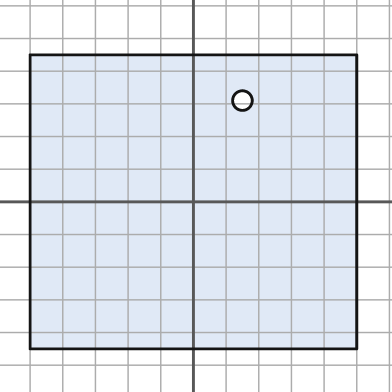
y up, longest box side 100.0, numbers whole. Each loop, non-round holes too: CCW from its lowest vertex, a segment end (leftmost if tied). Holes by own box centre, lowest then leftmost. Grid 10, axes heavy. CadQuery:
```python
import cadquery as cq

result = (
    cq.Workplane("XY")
    .moveTo(-50.0, -45.0)
    .lineTo(50.0, -45.0)
    .lineTo(50.0, 45.0)
    .lineTo(-50.0, 45.0)
    .close()
    .moveTo(15.0, 31.0)
    .circle(3.0)
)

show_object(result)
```